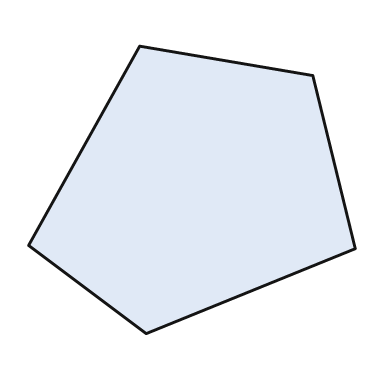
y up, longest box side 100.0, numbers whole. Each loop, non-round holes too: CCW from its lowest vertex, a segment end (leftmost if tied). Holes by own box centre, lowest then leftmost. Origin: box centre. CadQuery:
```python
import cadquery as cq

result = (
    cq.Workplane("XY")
    .moveTo(-14.0, -44.0)
    .lineTo(50.0, -18.0)
    .lineTo(37.0, 35.0)
    .lineTo(-16.0, 44.0)
    .lineTo(-50.0, -17.0)
    .close()
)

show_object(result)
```